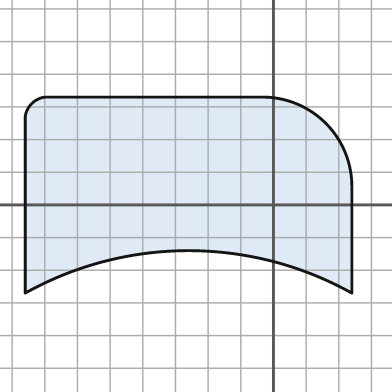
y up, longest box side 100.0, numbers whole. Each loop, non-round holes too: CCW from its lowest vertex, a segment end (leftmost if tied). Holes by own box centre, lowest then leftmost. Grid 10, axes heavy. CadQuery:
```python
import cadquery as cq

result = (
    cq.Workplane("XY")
    .moveTo(-76.0, -27.0)
    .threePointArc((-26.0, -14.0), (24.0, -27.0))
    .lineTo(24.0, 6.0)
    .threePointArc((16.0, 25.0), (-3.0, 33.0))
    .lineTo(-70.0, 33.0)
    .threePointArc((-74.0, 31.0), (-76.0, 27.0))
    .close()
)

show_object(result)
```